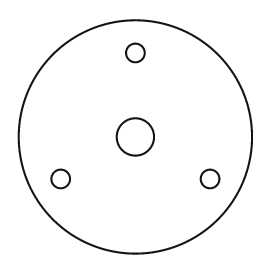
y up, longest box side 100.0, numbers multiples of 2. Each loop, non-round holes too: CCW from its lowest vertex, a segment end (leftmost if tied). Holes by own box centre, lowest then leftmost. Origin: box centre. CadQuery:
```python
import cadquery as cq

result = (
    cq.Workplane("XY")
    .moveTo(0.0, 0.0)
    .circle(50.0)
    .moveTo(-32.0, -18.0)
    .circle(4.0)
    .moveTo(32.0, -18.0)
    .circle(4.0)
    .moveTo(0.0, 0.0)
    .circle(8.0)
    .moveTo(0.0, 36.0)
    .circle(4.0)
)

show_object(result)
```